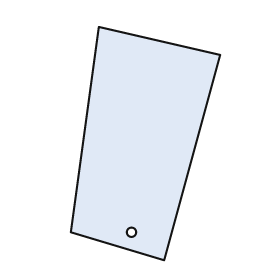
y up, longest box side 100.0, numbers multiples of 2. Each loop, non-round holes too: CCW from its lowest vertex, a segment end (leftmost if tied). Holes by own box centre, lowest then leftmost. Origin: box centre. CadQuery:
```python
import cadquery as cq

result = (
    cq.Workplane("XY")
    .moveTo(8.0, -50.0)
    .lineTo(32.0, 38.0)
    .lineTo(-20.0, 50.0)
    .lineTo(-32.0, -38.0)
    .close()
    .moveTo(-6.0, -38.0)
    .circle(2.0)
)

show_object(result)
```